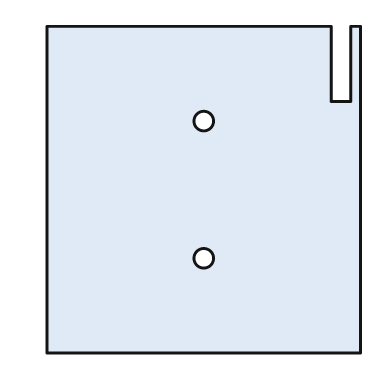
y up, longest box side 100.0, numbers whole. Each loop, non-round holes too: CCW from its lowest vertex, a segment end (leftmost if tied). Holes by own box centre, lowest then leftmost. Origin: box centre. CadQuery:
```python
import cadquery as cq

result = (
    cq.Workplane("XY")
    .moveTo(-48.0, -50.0)
    .lineTo(48.0, -50.0)
    .lineTo(48.0, 50.0)
    .lineTo(45.0, 50.0)
    .lineTo(45.0, 27.0)
    .lineTo(39.0, 27.0)
    .lineTo(39.0, 50.0)
    .lineTo(-48.0, 50.0)
    .close()
    .moveTo(0.0, -21.0)
    .circle(3.0)
    .moveTo(0.0, 21.0)
    .circle(3.0)
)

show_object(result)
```